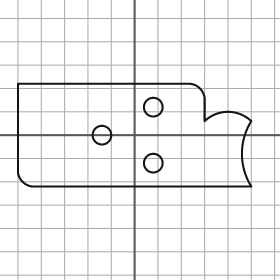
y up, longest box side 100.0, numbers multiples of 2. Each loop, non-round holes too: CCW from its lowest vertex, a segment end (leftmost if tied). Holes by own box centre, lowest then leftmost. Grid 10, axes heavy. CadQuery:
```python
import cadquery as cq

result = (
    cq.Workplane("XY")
    .moveTo(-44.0, -22.0)
    .lineTo(50.0, -22.0)
    .threePointArc((46.0, -8.0), (50.0, 6.0))
    .threePointArc((40.0, 10.0), (30.0, 6.0))
    .lineTo(30.0, 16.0)
    .threePointArc((28.0, 20.0), (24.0, 22.0))
    .lineTo(-50.0, 22.0)
    .lineTo(-50.0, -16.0)
    .threePointArc((-48.0, -20.0), (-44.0, -22.0))
    .close()
    .moveTo(8.0, -12.0)
    .circle(4.0)
    .moveTo(-14.0, 0.0)
    .circle(4.0)
    .moveTo(8.0, 12.0)
    .circle(4.0)
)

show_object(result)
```